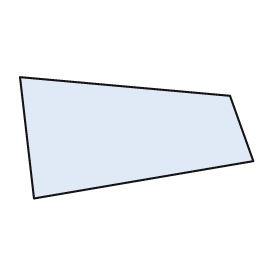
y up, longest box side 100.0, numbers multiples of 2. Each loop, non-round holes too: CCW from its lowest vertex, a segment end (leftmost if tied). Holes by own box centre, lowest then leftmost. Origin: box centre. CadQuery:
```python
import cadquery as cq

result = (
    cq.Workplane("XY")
    .moveTo(-44.0, -26.0)
    .lineTo(50.0, -10.0)
    .lineTo(40.0, 18.0)
    .lineTo(-50.0, 26.0)
    .close()
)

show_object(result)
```